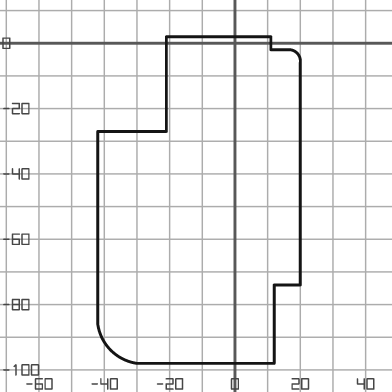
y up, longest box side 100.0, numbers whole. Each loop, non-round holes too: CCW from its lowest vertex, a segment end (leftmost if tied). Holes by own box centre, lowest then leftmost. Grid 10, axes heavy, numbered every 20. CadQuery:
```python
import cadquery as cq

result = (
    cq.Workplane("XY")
    .moveTo(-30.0, -98.0)
    .lineTo(12.0, -98.0)
    .lineTo(12.0, -74.0)
    .lineTo(20.0, -74.0)
    .lineTo(20.0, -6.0)
    .threePointArc((19.0, -3.0), (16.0, -2.0))
    .lineTo(11.0, -2.0)
    .lineTo(11.0, 2.0)
    .lineTo(-21.0, 2.0)
    .lineTo(-21.0, -27.0)
    .lineTo(-42.0, -27.0)
    .lineTo(-42.0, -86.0)
    .threePointArc((-38.0, -94.0), (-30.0, -98.0))
    .close()
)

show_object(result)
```